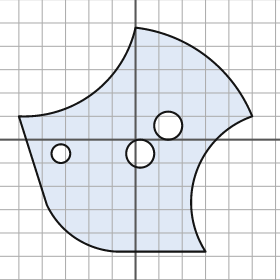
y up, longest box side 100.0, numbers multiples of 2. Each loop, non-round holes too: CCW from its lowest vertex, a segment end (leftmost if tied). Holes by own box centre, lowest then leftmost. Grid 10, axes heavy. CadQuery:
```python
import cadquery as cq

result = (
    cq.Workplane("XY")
    .moveTo(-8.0, -48.0)
    .lineTo(30.0, -48.0)
    .threePointArc((26.0, -14.0), (50.0, 10.0))
    .threePointArc((30.0, 36.0), (0.0, 48.0))
    .threePointArc((-18.0, 20.0), (-50.0, 10.0))
    .lineTo(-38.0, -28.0)
    .threePointArc((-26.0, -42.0), (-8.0, -48.0))
    .close()
    .moveTo(-32.0, -6.0)
    .circle(4.0)
    .moveTo(2.0, -6.0)
    .circle(6.0)
    .moveTo(14.0, 6.0)
    .circle(6.0)
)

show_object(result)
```